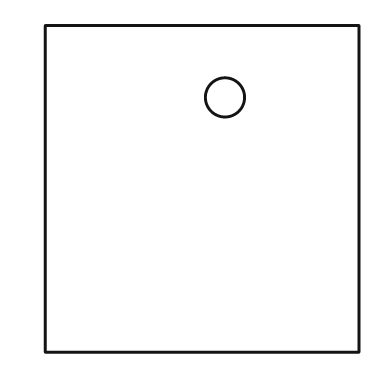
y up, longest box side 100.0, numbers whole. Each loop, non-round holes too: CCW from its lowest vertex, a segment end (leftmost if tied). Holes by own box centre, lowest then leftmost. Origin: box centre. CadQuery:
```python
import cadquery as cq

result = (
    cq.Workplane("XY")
    .moveTo(-48.0, -50.0)
    .lineTo(48.0, -50.0)
    .lineTo(48.0, 50.0)
    .lineTo(-48.0, 50.0)
    .close()
    .moveTo(7.0, 28.0)
    .circle(6.0)
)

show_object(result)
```